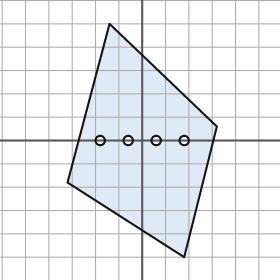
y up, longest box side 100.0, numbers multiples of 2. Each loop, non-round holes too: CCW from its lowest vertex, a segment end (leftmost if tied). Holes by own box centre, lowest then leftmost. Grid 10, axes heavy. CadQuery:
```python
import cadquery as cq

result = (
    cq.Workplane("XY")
    .moveTo(18.0, -50.0)
    .lineTo(32.0, 6.0)
    .lineTo(-14.0, 50.0)
    .lineTo(-32.0, -18.0)
    .close()
    .moveTo(-18.0, 0.0)
    .circle(2.0)
    .moveTo(-6.0, 0.0)
    .circle(2.0)
    .moveTo(6.0, 0.0)
    .circle(2.0)
    .moveTo(18.0, 0.0)
    .circle(2.0)
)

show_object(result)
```